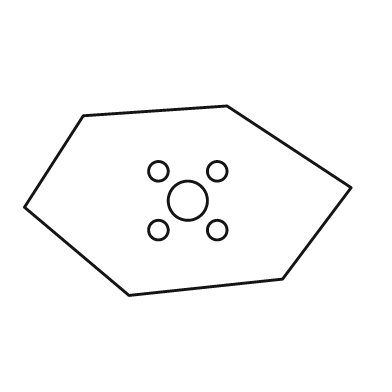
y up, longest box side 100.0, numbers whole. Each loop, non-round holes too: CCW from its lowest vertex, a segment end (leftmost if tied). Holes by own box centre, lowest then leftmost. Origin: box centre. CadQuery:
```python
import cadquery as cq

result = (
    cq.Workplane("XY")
    .moveTo(-18.0, -29.0)
    .lineTo(29.0, -24.0)
    .lineTo(50.0, 4.0)
    .lineTo(12.0, 29.0)
    .lineTo(-32.0, 26.0)
    .lineTo(-50.0, -2.0)
    .close()
    .moveTo(-9.0, -9.0)
    .circle(3.0)
    .moveTo(9.0, -9.0)
    .circle(3.0)
    .moveTo(0.0, 0.0)
    .circle(6.0)
    .moveTo(-9.0, 9.0)
    .circle(3.0)
    .moveTo(9.0, 9.0)
    .circle(3.0)
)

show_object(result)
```